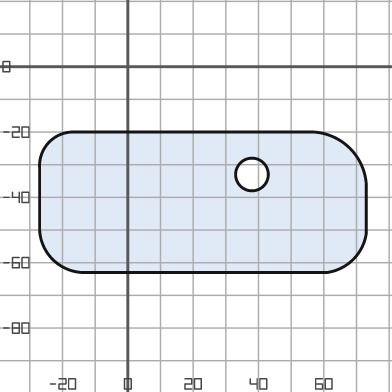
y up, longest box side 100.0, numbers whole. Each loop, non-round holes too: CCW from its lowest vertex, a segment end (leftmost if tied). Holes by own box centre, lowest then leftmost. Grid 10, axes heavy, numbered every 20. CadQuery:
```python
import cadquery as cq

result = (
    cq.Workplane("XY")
    .moveTo(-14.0, -63.0)
    .lineTo(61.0, -63.0)
    .threePointArc((69.0, -59.0), (73.0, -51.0))
    .lineTo(73.0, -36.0)
    .threePointArc((68.0, -25.0), (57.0, -20.0))
    .lineTo(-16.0, -20.0)
    .threePointArc((-24.0, -23.0), (-27.0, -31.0))
    .lineTo(-27.0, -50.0)
    .threePointArc((-23.0, -59.0), (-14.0, -63.0))
    .close()
    .moveTo(38.0, -33.0)
    .circle(5.0)
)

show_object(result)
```